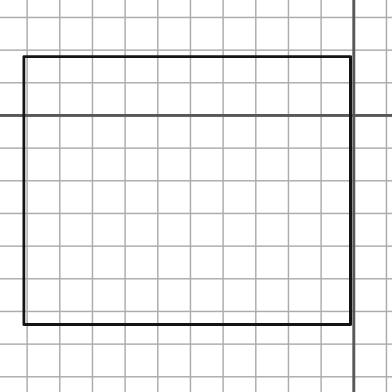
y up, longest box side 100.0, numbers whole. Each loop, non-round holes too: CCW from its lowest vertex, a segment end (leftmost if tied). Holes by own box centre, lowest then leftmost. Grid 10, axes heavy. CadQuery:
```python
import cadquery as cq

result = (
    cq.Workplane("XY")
    .moveTo(-101.0, -64.0)
    .lineTo(-1.0, -64.0)
    .lineTo(-1.0, 18.0)
    .lineTo(-101.0, 18.0)
    .close()
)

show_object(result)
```